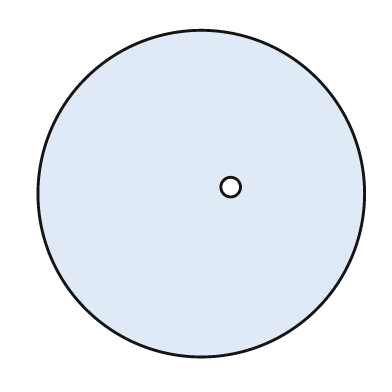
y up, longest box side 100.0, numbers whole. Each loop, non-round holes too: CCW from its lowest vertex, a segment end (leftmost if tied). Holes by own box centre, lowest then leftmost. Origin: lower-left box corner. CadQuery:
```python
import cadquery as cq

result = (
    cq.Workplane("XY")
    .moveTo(50.0, 50.0)
    .circle(50.0)
    .moveTo(59.0, 52.0)
    .circle(3.0)
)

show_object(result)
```